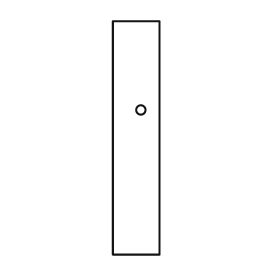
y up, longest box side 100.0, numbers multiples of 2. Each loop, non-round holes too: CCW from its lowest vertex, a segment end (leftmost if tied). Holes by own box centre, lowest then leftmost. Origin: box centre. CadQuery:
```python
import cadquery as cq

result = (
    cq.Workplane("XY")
    .moveTo(-10.0, -50.0)
    .lineTo(10.0, -50.0)
    .lineTo(10.0, 50.0)
    .lineTo(-10.0, 50.0)
    .close()
    .moveTo(2.0, 12.0)
    .circle(2.0)
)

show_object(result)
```